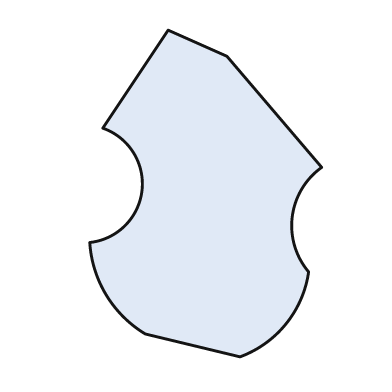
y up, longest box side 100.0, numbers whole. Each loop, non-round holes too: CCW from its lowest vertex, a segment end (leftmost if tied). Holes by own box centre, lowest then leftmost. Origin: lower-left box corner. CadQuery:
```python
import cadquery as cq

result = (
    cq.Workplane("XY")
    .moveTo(46.0, 0.0)
    .threePointArc((60.0, 10.0), (67.0, 26.0))
    .threePointArc((62.0, 43.0), (71.0, 58.0))
    .lineTo(42.0, 92.0)
    .lineTo(24.0, 100.0)
    .lineTo(4.0, 70.0)
    .threePointArc((16.0, 51.0), (0.0, 35.0))
    .threePointArc((5.0, 19.0), (17.0, 7.0))
    .close()
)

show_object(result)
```